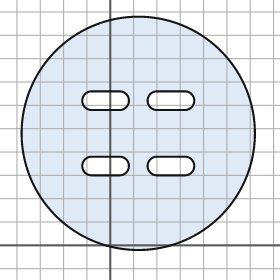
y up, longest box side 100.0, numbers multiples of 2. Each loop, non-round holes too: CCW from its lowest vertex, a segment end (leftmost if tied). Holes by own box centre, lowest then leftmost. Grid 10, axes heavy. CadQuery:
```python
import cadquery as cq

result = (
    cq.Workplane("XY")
    .moveTo(12.0, 48.0)
    .circle(50.0)
    .moveTo(-8.0, 30.0)
    .lineTo(4.0, 30.0)
    .threePointArc((8.0, 34.0), (4.0, 38.0))
    .lineTo(-8.0, 38.0)
    .threePointArc((-12.0, 34.0), (-8.0, 30.0))
    .close()
    .moveTo(20.0, 30.0)
    .lineTo(32.0, 30.0)
    .threePointArc((36.0, 34.0), (32.0, 38.0))
    .lineTo(20.0, 38.0)
    .threePointArc((16.0, 34.0), (20.0, 30.0))
    .close()
    .moveTo(-8.0, 58.0)
    .lineTo(4.0, 58.0)
    .threePointArc((8.0, 62.0), (4.0, 66.0))
    .lineTo(-8.0, 66.0)
    .threePointArc((-12.0, 62.0), (-8.0, 58.0))
    .close()
    .moveTo(20.0, 58.0)
    .lineTo(32.0, 58.0)
    .threePointArc((36.0, 62.0), (32.0, 66.0))
    .lineTo(20.0, 66.0)
    .threePointArc((16.0, 62.0), (20.0, 58.0))
    .close()
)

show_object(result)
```